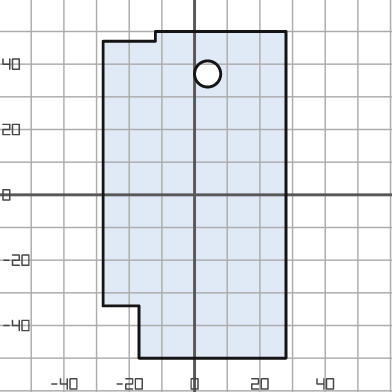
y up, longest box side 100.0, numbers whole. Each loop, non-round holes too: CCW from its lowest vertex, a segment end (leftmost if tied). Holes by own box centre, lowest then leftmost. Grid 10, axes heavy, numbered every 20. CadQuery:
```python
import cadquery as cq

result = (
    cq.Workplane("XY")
    .moveTo(-17.0, -50.0)
    .lineTo(28.0, -50.0)
    .lineTo(28.0, 50.0)
    .lineTo(-12.0, 50.0)
    .lineTo(-12.0, 47.0)
    .lineTo(-28.0, 47.0)
    .lineTo(-28.0, -34.0)
    .lineTo(-17.0, -34.0)
    .close()
    .moveTo(4.0, 37.0)
    .circle(4.0)
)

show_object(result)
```